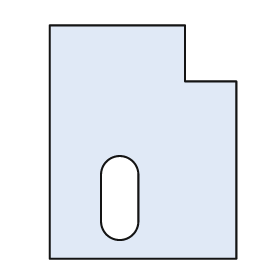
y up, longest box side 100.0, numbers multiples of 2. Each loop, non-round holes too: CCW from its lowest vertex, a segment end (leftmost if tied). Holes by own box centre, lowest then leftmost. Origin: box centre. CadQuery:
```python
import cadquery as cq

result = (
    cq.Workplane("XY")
    .moveTo(-40.0, -50.0)
    .lineTo(40.0, -50.0)
    .lineTo(40.0, 26.0)
    .lineTo(18.0, 26.0)
    .lineTo(18.0, 50.0)
    .lineTo(-40.0, 50.0)
    .close()
    .moveTo(-18.0, -34.0)
    .threePointArc((-10.0, -42.0), (-2.0, -34.0))
    .lineTo(-2.0, -14.0)
    .threePointArc((-10.0, -6.0), (-18.0, -14.0))
    .close()
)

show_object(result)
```